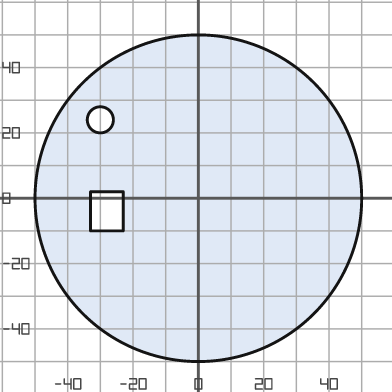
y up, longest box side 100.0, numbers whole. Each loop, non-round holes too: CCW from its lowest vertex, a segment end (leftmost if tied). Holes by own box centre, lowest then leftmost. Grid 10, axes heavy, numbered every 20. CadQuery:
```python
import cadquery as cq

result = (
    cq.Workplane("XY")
    .moveTo(0.0, 0.0)
    .circle(50.0)
    .moveTo(-33.0, -10.0)
    .lineTo(-23.0, -10.0)
    .lineTo(-23.0, 2.0)
    .lineTo(-33.0, 2.0)
    .close()
    .moveTo(-30.0, 24.0)
    .circle(4.0)
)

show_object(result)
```